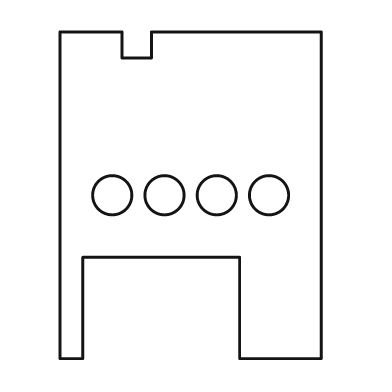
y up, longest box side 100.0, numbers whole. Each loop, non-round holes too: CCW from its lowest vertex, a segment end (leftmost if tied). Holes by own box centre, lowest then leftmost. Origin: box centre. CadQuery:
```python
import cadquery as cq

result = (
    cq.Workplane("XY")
    .moveTo(-40.0, -50.0)
    .lineTo(-33.0, -50.0)
    .lineTo(-33.0, -19.0)
    .lineTo(15.0, -19.0)
    .lineTo(15.0, -50.0)
    .lineTo(40.0, -50.0)
    .lineTo(40.0, 50.0)
    .lineTo(-12.0, 50.0)
    .lineTo(-12.0, 42.0)
    .lineTo(-21.0, 42.0)
    .lineTo(-21.0, 50.0)
    .lineTo(-40.0, 50.0)
    .close()
    .moveTo(-24.0, 0.0)
    .circle(6.0)
    .moveTo(-8.0, 0.0)
    .circle(6.0)
    .moveTo(8.0, 0.0)
    .circle(6.0)
    .moveTo(24.0, 0.0)
    .circle(6.0)
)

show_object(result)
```